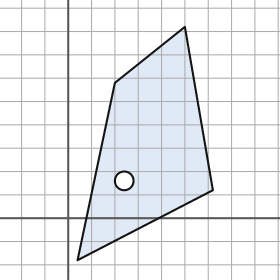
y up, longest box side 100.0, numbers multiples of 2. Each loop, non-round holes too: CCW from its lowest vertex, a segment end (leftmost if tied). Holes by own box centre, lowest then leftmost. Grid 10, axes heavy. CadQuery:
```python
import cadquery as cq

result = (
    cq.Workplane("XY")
    .moveTo(4.0, -18.0)
    .lineTo(62.0, 12.0)
    .lineTo(50.0, 82.0)
    .lineTo(20.0, 58.0)
    .close()
    .moveTo(24.0, 16.0)
    .circle(4.0)
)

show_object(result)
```